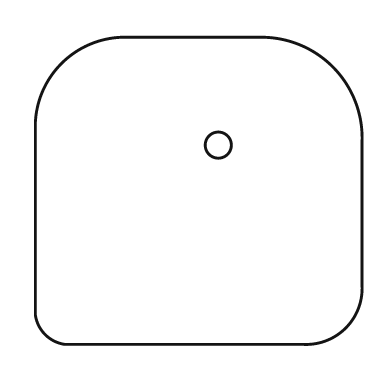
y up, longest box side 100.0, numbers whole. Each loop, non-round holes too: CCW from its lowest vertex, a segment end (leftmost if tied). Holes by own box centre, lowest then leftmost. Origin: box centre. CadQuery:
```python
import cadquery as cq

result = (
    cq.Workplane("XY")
    .moveTo(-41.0, -47.0)
    .lineTo(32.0, -47.0)
    .threePointArc((45.0, -42.0), (50.0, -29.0))
    .lineTo(50.0, 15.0)
    .threePointArc((41.0, 38.0), (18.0, 47.0))
    .lineTo(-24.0, 47.0)
    .threePointArc((-42.0, 39.0), (-50.0, 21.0))
    .lineTo(-50.0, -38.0)
    .threePointArc((-47.0, -44.0), (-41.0, -47.0))
    .close()
    .moveTo(6.0, 14.0)
    .circle(4.0)
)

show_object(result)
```